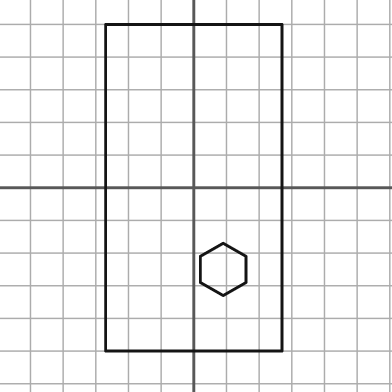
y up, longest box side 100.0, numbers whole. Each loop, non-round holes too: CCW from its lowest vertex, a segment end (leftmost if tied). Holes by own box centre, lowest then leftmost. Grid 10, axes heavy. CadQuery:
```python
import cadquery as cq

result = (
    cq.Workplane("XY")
    .moveTo(-27.0, -50.0)
    .lineTo(27.0, -50.0)
    .lineTo(27.0, 50.0)
    .lineTo(-27.0, 50.0)
    .close()
    .moveTo(9.0, -33.0)
    .lineTo(16.0, -29.0)
    .lineTo(16.0, -21.0)
    .lineTo(9.0, -17.0)
    .lineTo(2.0, -21.0)
    .lineTo(2.0, -29.0)
    .close()
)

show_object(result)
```